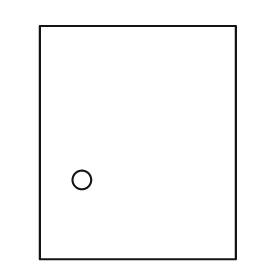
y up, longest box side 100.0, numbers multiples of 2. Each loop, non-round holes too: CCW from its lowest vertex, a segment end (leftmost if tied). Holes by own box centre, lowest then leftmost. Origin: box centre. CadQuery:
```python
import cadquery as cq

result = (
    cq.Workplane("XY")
    .moveTo(-42.0, -50.0)
    .lineTo(42.0, -50.0)
    .lineTo(42.0, 50.0)
    .lineTo(-42.0, 50.0)
    .close()
    .moveTo(-24.0, -16.0)
    .circle(4.0)
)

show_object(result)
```